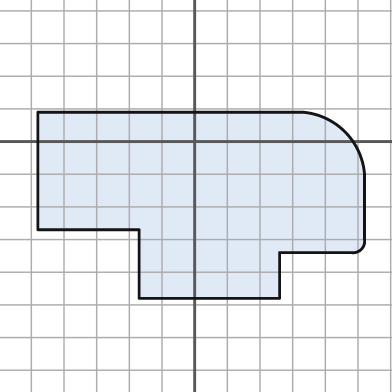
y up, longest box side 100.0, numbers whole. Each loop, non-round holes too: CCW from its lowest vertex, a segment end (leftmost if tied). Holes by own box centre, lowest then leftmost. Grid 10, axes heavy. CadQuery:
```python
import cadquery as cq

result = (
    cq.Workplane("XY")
    .moveTo(-17.0, -48.0)
    .lineTo(26.0, -48.0)
    .lineTo(26.0, -34.0)
    .lineTo(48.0, -34.0)
    .threePointArc((51.0, -33.0), (52.0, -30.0))
    .lineTo(52.0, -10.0)
    .threePointArc((46.0, 3.0), (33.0, 9.0))
    .lineTo(-48.0, 9.0)
    .lineTo(-48.0, -27.0)
    .lineTo(-17.0, -27.0)
    .close()
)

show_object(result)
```